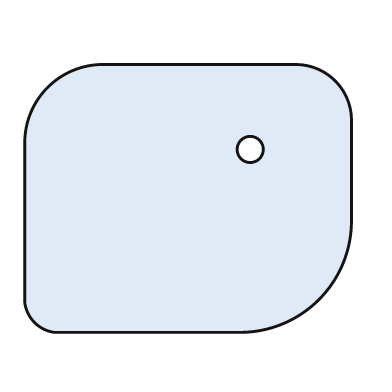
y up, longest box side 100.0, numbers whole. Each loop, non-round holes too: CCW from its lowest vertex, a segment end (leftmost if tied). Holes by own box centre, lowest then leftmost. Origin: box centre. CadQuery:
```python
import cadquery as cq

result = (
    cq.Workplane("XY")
    .moveTo(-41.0, -41.0)
    .lineTo(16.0, -41.0)
    .threePointArc((40.0, -31.0), (50.0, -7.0))
    .lineTo(50.0, 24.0)
    .threePointArc((45.0, 36.0), (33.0, 41.0))
    .lineTo(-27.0, 41.0)
    .threePointArc((-43.0, 34.0), (-50.0, 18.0))
    .lineTo(-50.0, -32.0)
    .threePointArc((-47.0, -38.0), (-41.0, -41.0))
    .close()
    .moveTo(19.0, 15.0)
    .circle(4.0)
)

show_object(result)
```